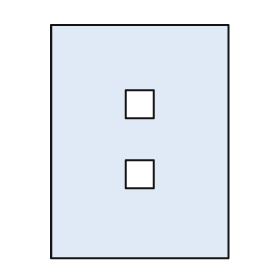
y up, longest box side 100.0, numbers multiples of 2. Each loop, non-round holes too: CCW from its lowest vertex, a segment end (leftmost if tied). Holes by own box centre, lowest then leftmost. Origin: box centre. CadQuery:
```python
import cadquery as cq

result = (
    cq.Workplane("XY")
    .moveTo(-38.0, -50.0)
    .lineTo(38.0, -50.0)
    .lineTo(38.0, 50.0)
    .lineTo(-38.0, 50.0)
    .close()
    .moveTo(-6.0, -20.0)
    .lineTo(6.0, -20.0)
    .lineTo(6.0, -8.0)
    .lineTo(-6.0, -8.0)
    .close()
    .moveTo(-6.0, 10.0)
    .lineTo(6.0, 10.0)
    .lineTo(6.0, 22.0)
    .lineTo(-6.0, 22.0)
    .close()
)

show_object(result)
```